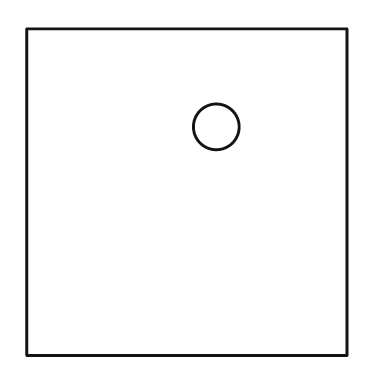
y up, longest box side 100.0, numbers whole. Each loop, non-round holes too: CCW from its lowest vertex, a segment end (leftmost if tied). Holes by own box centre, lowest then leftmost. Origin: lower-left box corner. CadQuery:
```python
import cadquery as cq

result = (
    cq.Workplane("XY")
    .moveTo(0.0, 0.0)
    .lineTo(98.0, 0.0)
    .lineTo(98.0, 100.0)
    .lineTo(0.0, 100.0)
    .close()
    .moveTo(58.0, 70.0)
    .circle(7.0)
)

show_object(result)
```